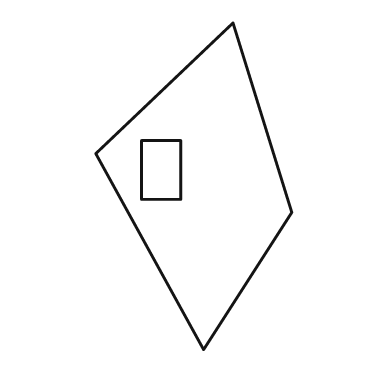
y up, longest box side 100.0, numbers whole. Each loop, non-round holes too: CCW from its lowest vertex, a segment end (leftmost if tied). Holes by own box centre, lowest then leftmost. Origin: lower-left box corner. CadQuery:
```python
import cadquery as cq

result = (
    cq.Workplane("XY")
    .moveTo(33.0, 0.0)
    .lineTo(60.0, 42.0)
    .lineTo(42.0, 100.0)
    .lineTo(0.0, 60.0)
    .close()
    .moveTo(14.0, 46.0)
    .lineTo(26.0, 46.0)
    .lineTo(26.0, 64.0)
    .lineTo(14.0, 64.0)
    .close()
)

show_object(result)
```